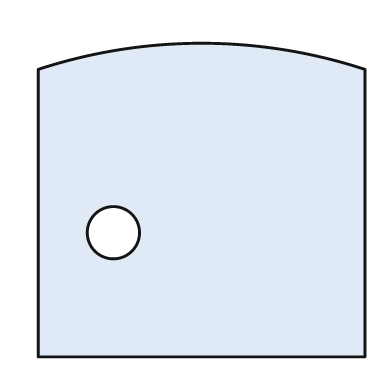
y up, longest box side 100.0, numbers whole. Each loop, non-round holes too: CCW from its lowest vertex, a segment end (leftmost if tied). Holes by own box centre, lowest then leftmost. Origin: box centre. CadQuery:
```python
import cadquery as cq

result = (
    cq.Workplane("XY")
    .moveTo(-50.0, -48.0)
    .lineTo(50.0, -48.0)
    .lineTo(50.0, 40.0)
    .threePointArc((0.0, 48.0), (-50.0, 40.0))
    .close()
    .moveTo(-27.0, -10.0)
    .circle(8.0)
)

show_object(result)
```